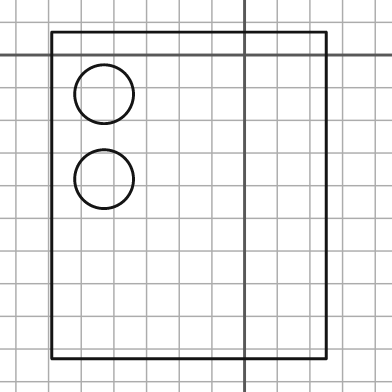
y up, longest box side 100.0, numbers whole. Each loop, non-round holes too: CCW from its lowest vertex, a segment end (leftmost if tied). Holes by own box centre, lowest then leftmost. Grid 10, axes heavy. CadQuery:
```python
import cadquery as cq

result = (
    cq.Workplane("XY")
    .moveTo(-59.0, -93.0)
    .lineTo(25.0, -93.0)
    .lineTo(25.0, 7.0)
    .lineTo(-59.0, 7.0)
    .close()
    .moveTo(-43.0, -38.0)
    .circle(9.0)
    .moveTo(-43.0, -12.0)
    .circle(9.0)
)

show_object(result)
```